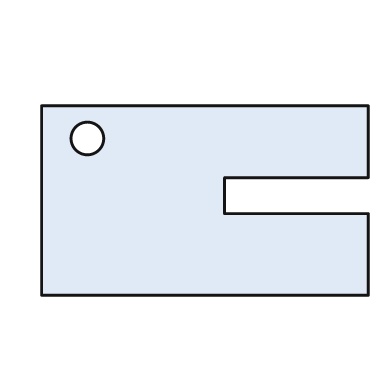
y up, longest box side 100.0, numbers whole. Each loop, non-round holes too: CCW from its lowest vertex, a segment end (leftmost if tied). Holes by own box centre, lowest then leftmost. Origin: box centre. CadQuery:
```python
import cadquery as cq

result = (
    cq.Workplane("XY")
    .moveTo(-50.0, -29.0)
    .lineTo(50.0, -29.0)
    .lineTo(50.0, -4.0)
    .lineTo(6.0, -4.0)
    .lineTo(6.0, 7.0)
    .lineTo(50.0, 7.0)
    .lineTo(50.0, 29.0)
    .lineTo(-50.0, 29.0)
    .close()
    .moveTo(-36.0, 19.0)
    .circle(5.0)
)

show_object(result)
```